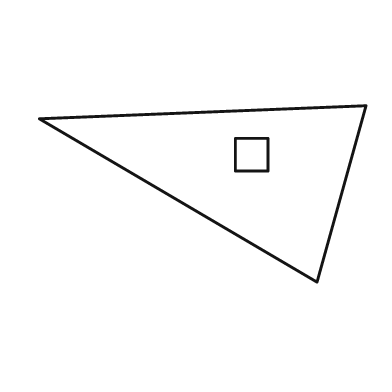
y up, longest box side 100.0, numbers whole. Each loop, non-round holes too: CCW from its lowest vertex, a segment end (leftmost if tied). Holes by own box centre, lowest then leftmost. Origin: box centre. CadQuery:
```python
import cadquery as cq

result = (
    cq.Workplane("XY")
    .moveTo(35.0, -27.0)
    .lineTo(50.0, 27.0)
    .lineTo(-50.0, 23.0)
    .close()
    .moveTo(10.0, 7.0)
    .lineTo(20.0, 7.0)
    .lineTo(20.0, 17.0)
    .lineTo(10.0, 17.0)
    .close()
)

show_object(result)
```